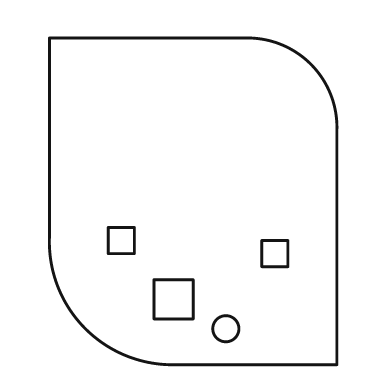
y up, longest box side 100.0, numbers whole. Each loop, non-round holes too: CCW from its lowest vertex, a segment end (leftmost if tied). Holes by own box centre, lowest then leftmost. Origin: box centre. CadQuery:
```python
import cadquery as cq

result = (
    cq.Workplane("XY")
    .moveTo(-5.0, -50.0)
    .lineTo(44.0, -50.0)
    .lineTo(44.0, 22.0)
    .threePointArc((36.0, 42.0), (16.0, 50.0))
    .lineTo(-44.0, 50.0)
    .lineTo(-44.0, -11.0)
    .threePointArc((-33.0, -39.0), (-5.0, -50.0))
    .close()
    .moveTo(10.0, -39.0)
    .circle(4.0)
    .moveTo(-12.0, -36.0)
    .lineTo(0.0, -36.0)
    .lineTo(0.0, -24.0)
    .lineTo(-12.0, -24.0)
    .close()
    .moveTo(21.0, -20.0)
    .lineTo(29.0, -20.0)
    .lineTo(29.0, -12.0)
    .lineTo(21.0, -12.0)
    .close()
    .moveTo(-26.0, -16.0)
    .lineTo(-18.0, -16.0)
    .lineTo(-18.0, -8.0)
    .lineTo(-26.0, -8.0)
    .close()
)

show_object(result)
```